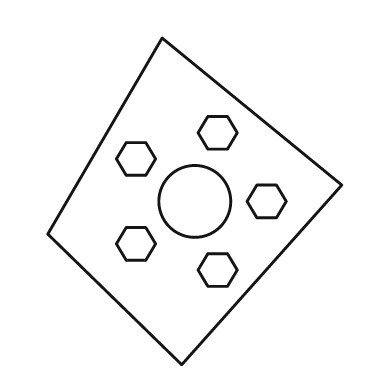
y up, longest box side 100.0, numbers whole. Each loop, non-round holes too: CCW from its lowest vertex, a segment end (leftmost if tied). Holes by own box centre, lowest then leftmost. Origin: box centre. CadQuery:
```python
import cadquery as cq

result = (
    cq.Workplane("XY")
    .moveTo(-4.0, -50.0)
    .lineTo(45.0, 5.0)
    .lineTo(-10.0, 50.0)
    .lineTo(-45.0, -10.0)
    .close()
    .moveTo(4.0, -26.0)
    .lineTo(10.0, -26.0)
    .lineTo(13.0, -21.0)
    .lineTo(10.0, -16.0)
    .lineTo(4.0, -16.0)
    .lineTo(1.0, -21.0)
    .close()
    .moveTo(-21.0, -18.0)
    .lineTo(-15.0, -18.0)
    .lineTo(-12.0, -13.0)
    .lineTo(-15.0, -8.0)
    .lineTo(-21.0, -8.0)
    .lineTo(-24.0, -13.0)
    .close()
    .moveTo(0.0, 0.0)
    .circle(11.0)
    .moveTo(19.0, -5.0)
    .lineTo(25.0, -5.0)
    .lineTo(28.0, 0.0)
    .lineTo(25.0, 5.0)
    .lineTo(19.0, 5.0)
    .lineTo(16.0, 0.0)
    .close()
    .moveTo(-21.0, 8.0)
    .lineTo(-15.0, 8.0)
    .lineTo(-12.0, 13.0)
    .lineTo(-15.0, 18.0)
    .lineTo(-21.0, 18.0)
    .lineTo(-24.0, 13.0)
    .close()
    .moveTo(4.0, 16.0)
    .lineTo(10.0, 16.0)
    .lineTo(13.0, 21.0)
    .lineTo(10.0, 26.0)
    .lineTo(4.0, 26.0)
    .lineTo(1.0, 21.0)
    .close()
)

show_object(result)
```